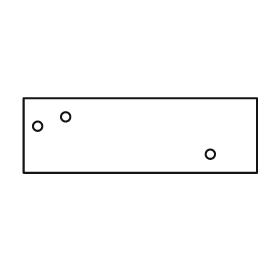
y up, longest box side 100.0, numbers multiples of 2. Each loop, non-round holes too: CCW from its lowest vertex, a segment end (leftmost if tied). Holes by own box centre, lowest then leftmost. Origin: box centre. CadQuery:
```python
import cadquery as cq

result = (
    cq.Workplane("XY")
    .moveTo(-50.0, -16.0)
    .lineTo(50.0, -16.0)
    .lineTo(50.0, 16.0)
    .lineTo(-50.0, 16.0)
    .close()
    .moveTo(30.0, -8.0)
    .circle(2.0)
    .moveTo(-44.0, 4.0)
    .circle(2.0)
    .moveTo(-32.0, 8.0)
    .circle(2.0)
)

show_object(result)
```